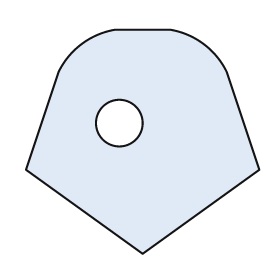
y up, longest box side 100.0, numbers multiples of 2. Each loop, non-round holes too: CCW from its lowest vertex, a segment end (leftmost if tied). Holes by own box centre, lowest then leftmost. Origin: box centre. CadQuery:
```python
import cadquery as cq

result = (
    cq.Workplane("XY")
    .moveTo(0.0, -48.0)
    .lineTo(50.0, -12.0)
    .lineTo(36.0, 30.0)
    .threePointArc((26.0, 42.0), (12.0, 48.0))
    .lineTo(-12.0, 48.0)
    .threePointArc((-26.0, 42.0), (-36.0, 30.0))
    .lineTo(-50.0, -12.0)
    .close()
    .moveTo(-10.0, 8.0)
    .circle(10.0)
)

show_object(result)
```